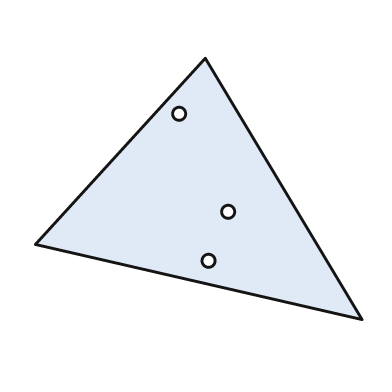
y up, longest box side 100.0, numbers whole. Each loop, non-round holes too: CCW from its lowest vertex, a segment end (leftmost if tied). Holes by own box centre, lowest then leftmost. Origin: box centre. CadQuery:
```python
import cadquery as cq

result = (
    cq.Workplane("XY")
    .moveTo(50.0, -40.0)
    .lineTo(2.0, 40.0)
    .lineTo(-50.0, -17.0)
    .close()
    .moveTo(3.0, -22.0)
    .circle(2.0)
    .moveTo(9.0, -7.0)
    .circle(2.0)
    .moveTo(-6.0, 23.0)
    .circle(2.0)
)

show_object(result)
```